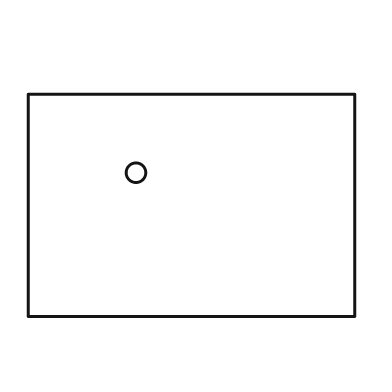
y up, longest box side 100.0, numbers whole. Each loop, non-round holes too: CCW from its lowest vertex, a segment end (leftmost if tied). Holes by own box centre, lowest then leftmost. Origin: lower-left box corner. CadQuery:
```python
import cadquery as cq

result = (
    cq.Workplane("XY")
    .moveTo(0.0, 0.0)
    .lineTo(100.0, 0.0)
    .lineTo(100.0, 68.0)
    .lineTo(0.0, 68.0)
    .close()
    .moveTo(33.0, 44.0)
    .circle(3.0)
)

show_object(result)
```